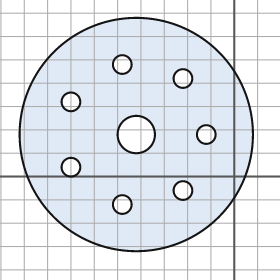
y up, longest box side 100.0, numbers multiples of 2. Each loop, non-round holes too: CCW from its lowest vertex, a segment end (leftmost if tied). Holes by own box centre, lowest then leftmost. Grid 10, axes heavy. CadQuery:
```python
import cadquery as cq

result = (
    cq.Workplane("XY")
    .moveTo(-42.0, 18.0)
    .circle(50.0)
    .moveTo(-48.0, -12.0)
    .circle(4.0)
    .moveTo(-22.0, -6.0)
    .circle(4.0)
    .moveTo(-70.0, 4.0)
    .circle(4.0)
    .moveTo(-42.0, 18.0)
    .circle(8.0)
    .moveTo(-12.0, 18.0)
    .circle(4.0)
    .moveTo(-70.0, 32.0)
    .circle(4.0)
    .moveTo(-22.0, 42.0)
    .circle(4.0)
    .moveTo(-48.0, 48.0)
    .circle(4.0)
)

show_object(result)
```